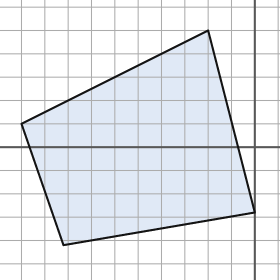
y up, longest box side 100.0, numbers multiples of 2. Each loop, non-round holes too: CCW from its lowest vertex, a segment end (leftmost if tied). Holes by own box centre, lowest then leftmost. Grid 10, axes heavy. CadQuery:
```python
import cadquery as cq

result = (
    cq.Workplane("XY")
    .moveTo(-82.0, -42.0)
    .lineTo(0.0, -28.0)
    .lineTo(-20.0, 50.0)
    .lineTo(-100.0, 10.0)
    .close()
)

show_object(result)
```